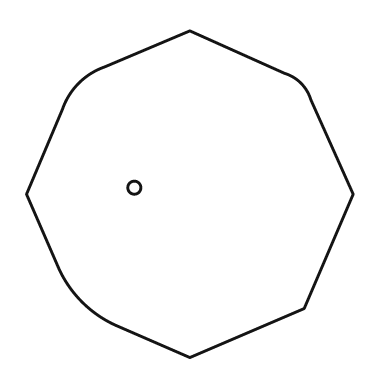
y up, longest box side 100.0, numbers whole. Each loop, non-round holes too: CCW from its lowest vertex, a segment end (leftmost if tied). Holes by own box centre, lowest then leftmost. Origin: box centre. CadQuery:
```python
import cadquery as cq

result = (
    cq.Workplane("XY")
    .moveTo(0.0, -50.0)
    .lineTo(35.0, -35.0)
    .lineTo(50.0, 0.0)
    .lineTo(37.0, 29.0)
    .threePointArc((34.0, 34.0), (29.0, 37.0))
    .lineTo(0.0, 50.0)
    .lineTo(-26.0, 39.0)
    .threePointArc((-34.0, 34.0), (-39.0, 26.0))
    .lineTo(-50.0, 0.0)
    .lineTo(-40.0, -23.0)
    .threePointArc((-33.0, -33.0), (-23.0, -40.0))
    .close()
    .moveTo(-17.0, 2.0)
    .circle(2.0)
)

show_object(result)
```